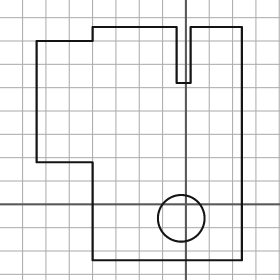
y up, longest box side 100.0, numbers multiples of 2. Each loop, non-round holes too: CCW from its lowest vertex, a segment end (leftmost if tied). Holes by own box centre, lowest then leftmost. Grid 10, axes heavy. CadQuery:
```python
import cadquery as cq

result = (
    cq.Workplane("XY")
    .moveTo(-40.0, -24.0)
    .lineTo(24.0, -24.0)
    .lineTo(24.0, 76.0)
    .lineTo(2.0, 76.0)
    .lineTo(2.0, 52.0)
    .lineTo(-4.0, 52.0)
    .lineTo(-4.0, 76.0)
    .lineTo(-40.0, 76.0)
    .lineTo(-40.0, 70.0)
    .lineTo(-64.0, 70.0)
    .lineTo(-64.0, 18.0)
    .lineTo(-40.0, 18.0)
    .close()
    .moveTo(-2.0, -6.0)
    .circle(10.0)
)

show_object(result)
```